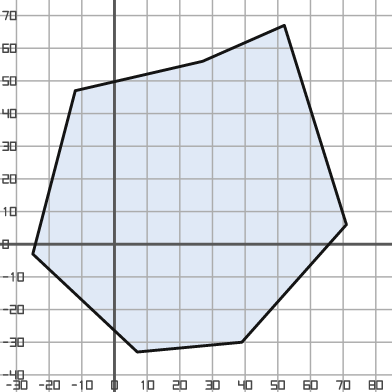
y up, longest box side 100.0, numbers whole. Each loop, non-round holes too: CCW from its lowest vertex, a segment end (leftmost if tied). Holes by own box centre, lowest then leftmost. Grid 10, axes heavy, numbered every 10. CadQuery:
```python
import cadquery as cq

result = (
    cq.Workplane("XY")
    .moveTo(7.0, -33.0)
    .lineTo(39.0, -30.0)
    .lineTo(71.0, 6.0)
    .lineTo(52.0, 67.0)
    .lineTo(27.0, 56.0)
    .lineTo(-12.0, 47.0)
    .lineTo(-25.0, -3.0)
    .close()
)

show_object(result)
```